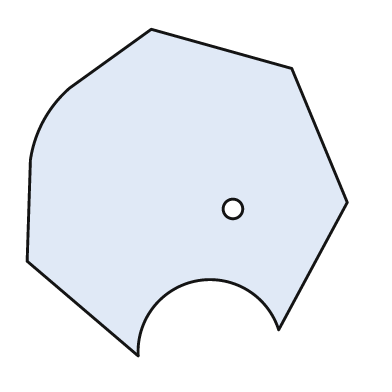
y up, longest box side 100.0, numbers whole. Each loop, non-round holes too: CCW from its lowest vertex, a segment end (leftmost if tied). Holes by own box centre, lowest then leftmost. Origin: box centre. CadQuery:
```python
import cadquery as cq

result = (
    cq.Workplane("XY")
    .moveTo(-15.0, -50.0)
    .threePointArc((3.0, -27.0), (28.0, -42.0))
    .lineTo(49.0, -3.0)
    .lineTo(32.0, 38.0)
    .lineTo(-11.0, 50.0)
    .lineTo(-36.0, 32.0)
    .threePointArc((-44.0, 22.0), (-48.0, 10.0))
    .lineTo(-49.0, -21.0)
    .close()
    .moveTo(14.0, -5.0)
    .circle(3.0)
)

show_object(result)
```